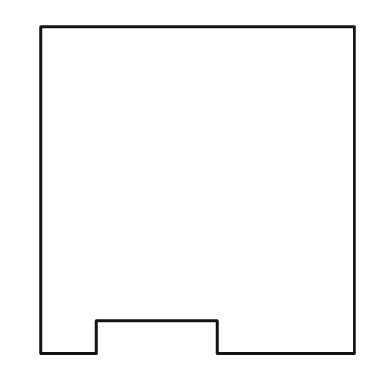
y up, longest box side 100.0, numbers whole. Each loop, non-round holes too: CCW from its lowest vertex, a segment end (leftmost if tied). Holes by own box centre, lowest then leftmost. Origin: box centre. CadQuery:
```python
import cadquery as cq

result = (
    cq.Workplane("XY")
    .moveTo(-48.0, -50.0)
    .lineTo(-31.0, -50.0)
    .lineTo(-31.0, -40.0)
    .lineTo(6.0, -40.0)
    .lineTo(6.0, -50.0)
    .lineTo(48.0, -50.0)
    .lineTo(48.0, 50.0)
    .lineTo(-48.0, 50.0)
    .close()
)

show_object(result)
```